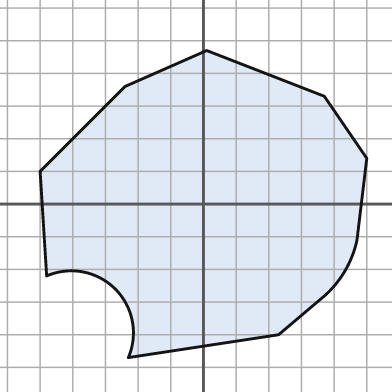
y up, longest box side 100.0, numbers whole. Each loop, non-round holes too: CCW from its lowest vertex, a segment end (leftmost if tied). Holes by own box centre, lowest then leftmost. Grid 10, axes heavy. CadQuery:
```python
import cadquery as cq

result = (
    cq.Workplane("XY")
    .moveTo(-23.0, -47.0)
    .lineTo(23.0, -40.0)
    .lineTo(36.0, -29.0)
    .threePointArc((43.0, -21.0), (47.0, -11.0))
    .lineTo(50.0, 14.0)
    .lineTo(37.0, 33.0)
    .lineTo(1.0, 47.0)
    .lineTo(-24.0, 36.0)
    .lineTo(-50.0, 10.0)
    .lineTo(-48.0, -22.0)
    .threePointArc((-27.0, -26.0), (-23.0, -47.0))
    .close()
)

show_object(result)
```